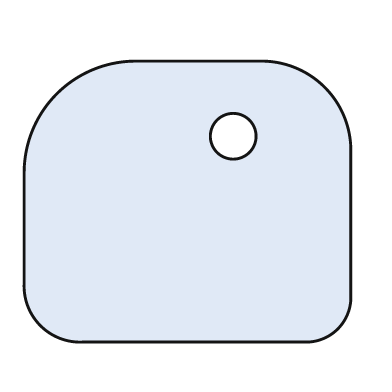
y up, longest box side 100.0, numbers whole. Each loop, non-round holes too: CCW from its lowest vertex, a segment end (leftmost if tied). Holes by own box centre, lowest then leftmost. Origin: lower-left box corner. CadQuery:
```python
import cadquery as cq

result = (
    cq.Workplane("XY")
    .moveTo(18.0, 0.0)
    .lineTo(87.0, 0.0)
    .threePointArc((96.0, 4.0), (100.0, 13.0))
    .lineTo(100.0, 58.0)
    .threePointArc((92.0, 78.0), (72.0, 86.0))
    .lineTo(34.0, 86.0)
    .threePointArc((10.0, 76.0), (0.0, 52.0))
    .lineTo(0.0, 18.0)
    .threePointArc((5.0, 5.0), (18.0, 0.0))
    .close()
    .moveTo(64.0, 63.0)
    .circle(7.0)
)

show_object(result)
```